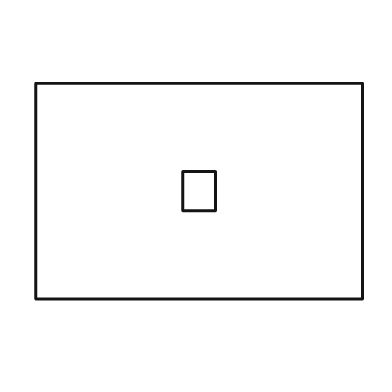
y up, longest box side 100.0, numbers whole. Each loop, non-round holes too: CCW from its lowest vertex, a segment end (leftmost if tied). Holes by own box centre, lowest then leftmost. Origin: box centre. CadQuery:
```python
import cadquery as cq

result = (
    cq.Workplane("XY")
    .moveTo(-50.0, -33.0)
    .lineTo(50.0, -33.0)
    .lineTo(50.0, 33.0)
    .lineTo(-50.0, 33.0)
    .close()
    .moveTo(-5.0, -6.0)
    .lineTo(5.0, -6.0)
    .lineTo(5.0, 6.0)
    .lineTo(-5.0, 6.0)
    .close()
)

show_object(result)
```